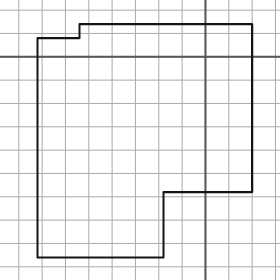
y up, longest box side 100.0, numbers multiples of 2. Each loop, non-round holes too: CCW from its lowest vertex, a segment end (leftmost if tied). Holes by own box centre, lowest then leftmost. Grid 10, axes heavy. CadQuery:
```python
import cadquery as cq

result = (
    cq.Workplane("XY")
    .moveTo(-72.0, -86.0)
    .lineTo(-18.0, -86.0)
    .lineTo(-18.0, -58.0)
    .lineTo(20.0, -58.0)
    .lineTo(20.0, 14.0)
    .lineTo(-54.0, 14.0)
    .lineTo(-54.0, 8.0)
    .lineTo(-72.0, 8.0)
    .close()
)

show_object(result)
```